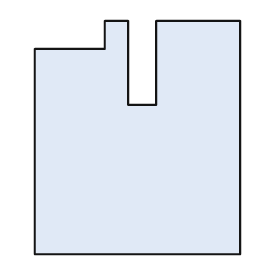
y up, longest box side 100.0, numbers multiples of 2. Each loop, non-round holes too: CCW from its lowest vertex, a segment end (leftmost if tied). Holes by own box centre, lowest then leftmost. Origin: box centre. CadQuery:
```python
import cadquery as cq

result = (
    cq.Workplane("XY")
    .moveTo(-44.0, -50.0)
    .lineTo(44.0, -50.0)
    .lineTo(44.0, 50.0)
    .lineTo(8.0, 50.0)
    .lineTo(8.0, 14.0)
    .lineTo(-4.0, 14.0)
    .lineTo(-4.0, 50.0)
    .lineTo(-14.0, 50.0)
    .lineTo(-14.0, 38.0)
    .lineTo(-44.0, 38.0)
    .close()
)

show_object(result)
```